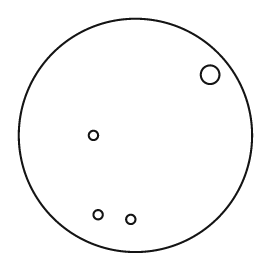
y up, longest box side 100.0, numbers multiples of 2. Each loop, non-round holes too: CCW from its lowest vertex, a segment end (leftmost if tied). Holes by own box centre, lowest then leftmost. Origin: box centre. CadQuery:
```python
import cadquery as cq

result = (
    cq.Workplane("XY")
    .moveTo(0.0, 0.0)
    .circle(50.0)
    .moveTo(-2.0, -36.0)
    .circle(2.0)
    .moveTo(-16.0, -34.0)
    .circle(2.0)
    .moveTo(-18.0, 0.0)
    .circle(2.0)
    .moveTo(32.0, 26.0)
    .circle(4.0)
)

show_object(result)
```